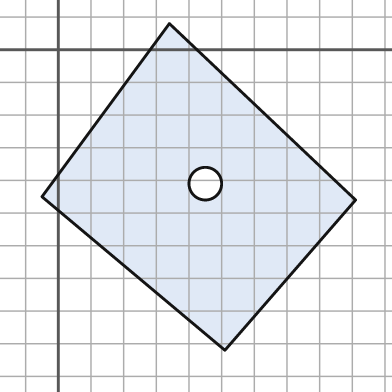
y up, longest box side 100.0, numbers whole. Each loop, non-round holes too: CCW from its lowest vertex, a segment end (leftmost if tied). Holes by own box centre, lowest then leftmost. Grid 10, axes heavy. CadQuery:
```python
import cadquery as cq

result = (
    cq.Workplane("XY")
    .moveTo(51.0, -92.0)
    .lineTo(91.0, -46.0)
    .lineTo(34.0, 8.0)
    .lineTo(-5.0, -45.0)
    .close()
    .moveTo(45.0, -41.0)
    .circle(5.0)
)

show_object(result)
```